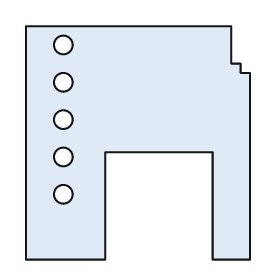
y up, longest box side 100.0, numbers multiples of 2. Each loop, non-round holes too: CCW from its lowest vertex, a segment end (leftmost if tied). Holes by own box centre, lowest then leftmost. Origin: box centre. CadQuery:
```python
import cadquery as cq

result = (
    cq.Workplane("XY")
    .moveTo(-48.0, -50.0)
    .lineTo(-14.0, -50.0)
    .lineTo(-14.0, -4.0)
    .lineTo(32.0, -4.0)
    .lineTo(32.0, -50.0)
    .lineTo(48.0, -50.0)
    .lineTo(48.0, 30.0)
    .lineTo(44.0, 30.0)
    .lineTo(44.0, 34.0)
    .lineTo(40.0, 34.0)
    .lineTo(40.0, 50.0)
    .lineTo(-48.0, 50.0)
    .close()
    .moveTo(-32.0, -22.0)
    .circle(4.0)
    .moveTo(-32.0, -6.0)
    .circle(4.0)
    .moveTo(-32.0, 10.0)
    .circle(4.0)
    .moveTo(-32.0, 26.0)
    .circle(4.0)
    .moveTo(-32.0, 42.0)
    .circle(4.0)
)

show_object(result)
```